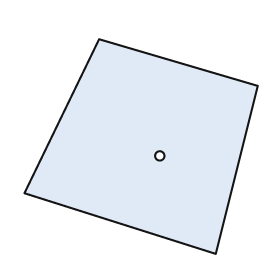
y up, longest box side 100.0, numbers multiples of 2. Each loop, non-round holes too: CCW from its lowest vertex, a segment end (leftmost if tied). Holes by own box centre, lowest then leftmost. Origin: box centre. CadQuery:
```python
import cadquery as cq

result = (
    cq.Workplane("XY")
    .moveTo(32.0, -46.0)
    .lineTo(50.0, 26.0)
    .lineTo(-18.0, 46.0)
    .lineTo(-50.0, -20.0)
    .close()
    .moveTo(8.0, -4.0)
    .circle(2.0)
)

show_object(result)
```